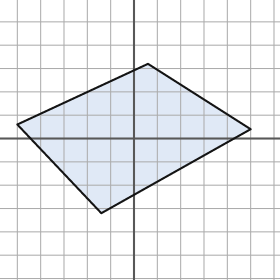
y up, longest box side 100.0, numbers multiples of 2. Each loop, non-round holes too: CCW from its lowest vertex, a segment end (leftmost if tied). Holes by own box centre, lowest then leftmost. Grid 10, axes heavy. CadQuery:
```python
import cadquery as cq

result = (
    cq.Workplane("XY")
    .moveTo(-14.0, -32.0)
    .lineTo(50.0, 4.0)
    .lineTo(6.0, 32.0)
    .lineTo(-50.0, 6.0)
    .close()
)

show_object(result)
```